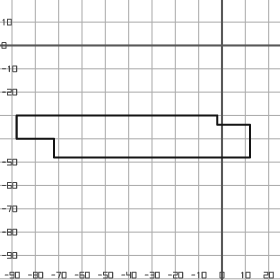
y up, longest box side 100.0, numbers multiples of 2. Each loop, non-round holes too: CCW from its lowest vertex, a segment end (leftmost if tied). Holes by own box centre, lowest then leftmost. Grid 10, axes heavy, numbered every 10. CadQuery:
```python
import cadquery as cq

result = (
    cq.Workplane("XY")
    .moveTo(-72.0, -48.0)
    .lineTo(12.0, -48.0)
    .lineTo(12.0, -34.0)
    .lineTo(-2.0, -34.0)
    .lineTo(-2.0, -30.0)
    .lineTo(-88.0, -30.0)
    .lineTo(-88.0, -40.0)
    .lineTo(-72.0, -40.0)
    .close()
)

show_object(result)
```